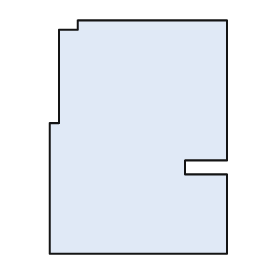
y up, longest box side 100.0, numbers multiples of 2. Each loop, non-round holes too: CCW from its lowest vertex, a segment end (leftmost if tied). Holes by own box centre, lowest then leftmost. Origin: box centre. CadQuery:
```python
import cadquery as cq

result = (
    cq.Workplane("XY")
    .moveTo(-38.0, -50.0)
    .lineTo(38.0, -50.0)
    .lineTo(38.0, -16.0)
    .lineTo(20.0, -16.0)
    .lineTo(20.0, -10.0)
    .lineTo(38.0, -10.0)
    .lineTo(38.0, 50.0)
    .lineTo(-26.0, 50.0)
    .lineTo(-26.0, 46.0)
    .lineTo(-34.0, 46.0)
    .lineTo(-34.0, 6.0)
    .lineTo(-38.0, 6.0)
    .close()
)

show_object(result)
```